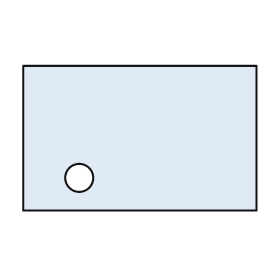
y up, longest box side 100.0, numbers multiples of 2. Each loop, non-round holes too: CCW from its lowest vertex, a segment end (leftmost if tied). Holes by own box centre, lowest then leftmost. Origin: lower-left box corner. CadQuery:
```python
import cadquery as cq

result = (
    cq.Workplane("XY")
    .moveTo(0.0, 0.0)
    .lineTo(100.0, 0.0)
    .lineTo(100.0, 62.0)
    .lineTo(0.0, 62.0)
    .close()
    .moveTo(24.0, 14.0)
    .circle(6.0)
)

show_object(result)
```